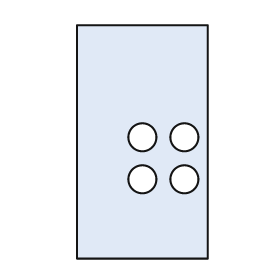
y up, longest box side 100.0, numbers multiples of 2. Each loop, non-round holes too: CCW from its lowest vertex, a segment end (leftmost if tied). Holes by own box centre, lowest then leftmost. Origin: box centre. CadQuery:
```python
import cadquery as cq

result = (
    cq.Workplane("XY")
    .moveTo(-28.0, -50.0)
    .lineTo(28.0, -50.0)
    .lineTo(28.0, 50.0)
    .lineTo(-28.0, 50.0)
    .close()
    .moveTo(0.0, -16.0)
    .circle(6.0)
    .moveTo(18.0, -16.0)
    .circle(6.0)
    .moveTo(0.0, 2.0)
    .circle(6.0)
    .moveTo(18.0, 2.0)
    .circle(6.0)
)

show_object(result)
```